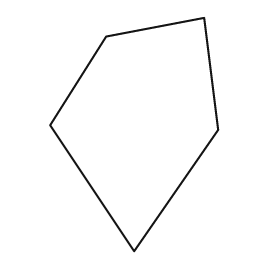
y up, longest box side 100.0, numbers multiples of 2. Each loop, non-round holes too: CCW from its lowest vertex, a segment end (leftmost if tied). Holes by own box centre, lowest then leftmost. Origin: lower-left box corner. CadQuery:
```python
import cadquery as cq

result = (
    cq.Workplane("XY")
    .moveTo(36.0, 0.0)
    .lineTo(72.0, 52.0)
    .lineTo(66.0, 100.0)
    .lineTo(24.0, 92.0)
    .lineTo(0.0, 54.0)
    .close()
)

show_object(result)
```